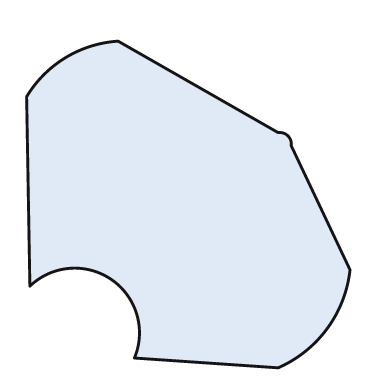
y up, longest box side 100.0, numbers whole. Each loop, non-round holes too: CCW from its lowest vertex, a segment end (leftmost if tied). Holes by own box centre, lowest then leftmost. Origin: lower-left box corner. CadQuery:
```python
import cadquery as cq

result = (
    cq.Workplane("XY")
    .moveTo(77.0, 0.0)
    .threePointArc((92.0, 12.0), (99.0, 30.0))
    .lineTo(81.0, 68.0)
    .threePointArc((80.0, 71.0), (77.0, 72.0))
    .lineTo(28.0, 100.0)
    .threePointArc((12.0, 95.0), (0.0, 83.0))
    .lineTo(1.0, 25.0)
    .threePointArc((26.0, 27.0), (33.0, 3.0))
    .close()
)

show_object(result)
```